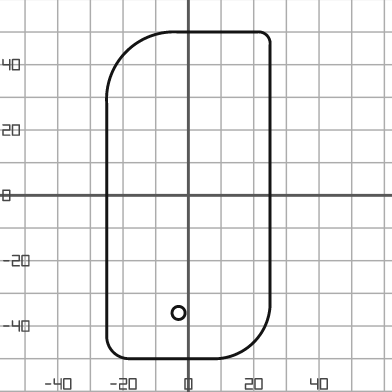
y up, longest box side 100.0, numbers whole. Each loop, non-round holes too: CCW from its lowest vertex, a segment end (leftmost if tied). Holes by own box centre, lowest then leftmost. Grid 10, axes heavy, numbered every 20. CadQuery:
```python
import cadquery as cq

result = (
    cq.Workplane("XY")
    .moveTo(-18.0, -50.0)
    .lineTo(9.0, -50.0)
    .threePointArc((20.0, -45.0), (25.0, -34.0))
    .lineTo(25.0, 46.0)
    .threePointArc((24.0, 49.0), (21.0, 50.0))
    .lineTo(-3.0, 50.0)
    .threePointArc((-19.0, 44.0), (-25.0, 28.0))
    .lineTo(-25.0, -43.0)
    .threePointArc((-23.0, -48.0), (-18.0, -50.0))
    .close()
    .moveTo(-3.0, -36.0)
    .circle(2.0)
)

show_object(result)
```